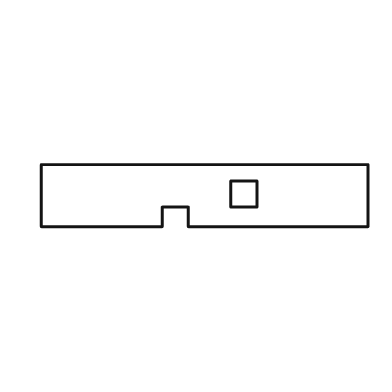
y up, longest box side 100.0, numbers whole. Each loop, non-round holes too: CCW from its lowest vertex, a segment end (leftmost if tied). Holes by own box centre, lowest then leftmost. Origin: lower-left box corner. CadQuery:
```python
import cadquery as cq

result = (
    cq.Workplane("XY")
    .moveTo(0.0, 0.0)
    .lineTo(37.0, 0.0)
    .lineTo(37.0, 6.0)
    .lineTo(45.0, 6.0)
    .lineTo(45.0, 0.0)
    .lineTo(100.0, 0.0)
    .lineTo(100.0, 19.0)
    .lineTo(0.0, 19.0)
    .close()
    .moveTo(58.0, 6.0)
    .lineTo(66.0, 6.0)
    .lineTo(66.0, 14.0)
    .lineTo(58.0, 14.0)
    .close()
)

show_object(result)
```